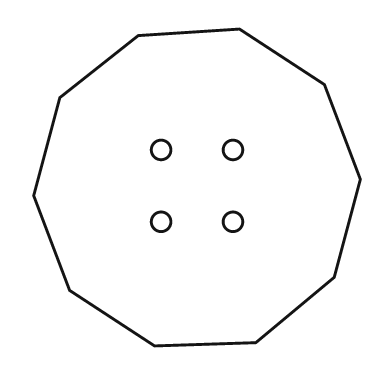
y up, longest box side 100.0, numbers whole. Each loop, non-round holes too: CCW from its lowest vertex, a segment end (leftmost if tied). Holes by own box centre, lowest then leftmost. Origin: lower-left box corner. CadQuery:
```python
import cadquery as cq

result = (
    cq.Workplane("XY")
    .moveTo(37.0, 0.0)
    .lineTo(68.0, 1.0)
    .lineTo(92.0, 21.0)
    .lineTo(100.0, 51.0)
    .lineTo(89.0, 80.0)
    .lineTo(63.0, 97.0)
    .lineTo(32.0, 95.0)
    .lineTo(8.0, 76.0)
    .lineTo(0.0, 46.0)
    .lineTo(11.0, 17.0)
    .close()
    .moveTo(39.0, 38.0)
    .circle(3.0)
    .moveTo(61.0, 38.0)
    .circle(3.0)
    .moveTo(39.0, 60.0)
    .circle(3.0)
    .moveTo(61.0, 60.0)
    .circle(3.0)
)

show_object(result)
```